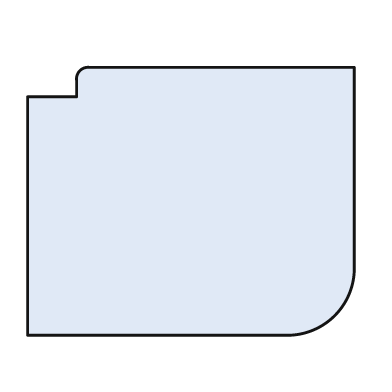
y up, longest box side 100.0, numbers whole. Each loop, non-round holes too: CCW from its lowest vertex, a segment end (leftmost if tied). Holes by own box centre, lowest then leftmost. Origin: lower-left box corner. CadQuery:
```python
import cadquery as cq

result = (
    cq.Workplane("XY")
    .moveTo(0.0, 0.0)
    .lineTo(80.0, 0.0)
    .threePointArc((94.0, 6.0), (100.0, 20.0))
    .lineTo(100.0, 82.0)
    .lineTo(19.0, 82.0)
    .threePointArc((16.0, 81.0), (15.0, 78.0))
    .lineTo(15.0, 73.0)
    .lineTo(0.0, 73.0)
    .close()
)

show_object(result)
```